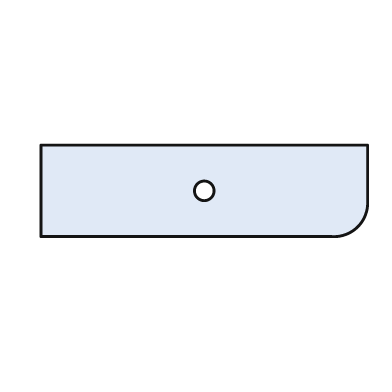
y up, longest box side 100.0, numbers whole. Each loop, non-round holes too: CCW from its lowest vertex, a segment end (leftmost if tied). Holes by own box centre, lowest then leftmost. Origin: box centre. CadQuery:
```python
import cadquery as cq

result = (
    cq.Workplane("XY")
    .moveTo(-50.0, -14.0)
    .lineTo(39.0, -14.0)
    .threePointArc((47.0, -11.0), (50.0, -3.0))
    .lineTo(50.0, 14.0)
    .lineTo(-50.0, 14.0)
    .close()
    .moveTo(0.0, 0.0)
    .circle(3.0)
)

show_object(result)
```